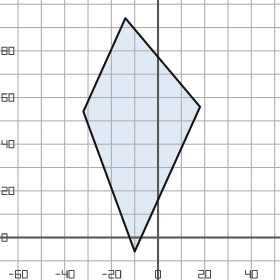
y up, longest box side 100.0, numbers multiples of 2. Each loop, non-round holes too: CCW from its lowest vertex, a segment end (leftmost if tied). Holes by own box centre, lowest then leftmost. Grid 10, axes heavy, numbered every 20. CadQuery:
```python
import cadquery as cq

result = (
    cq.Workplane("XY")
    .moveTo(-10.0, -6.0)
    .lineTo(18.0, 56.0)
    .lineTo(-14.0, 94.0)
    .lineTo(-32.0, 54.0)
    .close()
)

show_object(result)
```